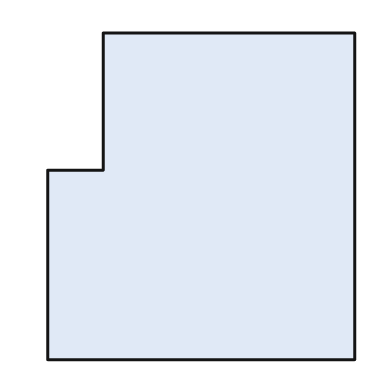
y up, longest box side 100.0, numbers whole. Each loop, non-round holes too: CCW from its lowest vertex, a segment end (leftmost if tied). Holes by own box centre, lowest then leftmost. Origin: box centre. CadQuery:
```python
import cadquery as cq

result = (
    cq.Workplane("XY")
    .moveTo(-47.0, -50.0)
    .lineTo(47.0, -50.0)
    .lineTo(47.0, 50.0)
    .lineTo(-30.0, 50.0)
    .lineTo(-30.0, 8.0)
    .lineTo(-47.0, 8.0)
    .close()
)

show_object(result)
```